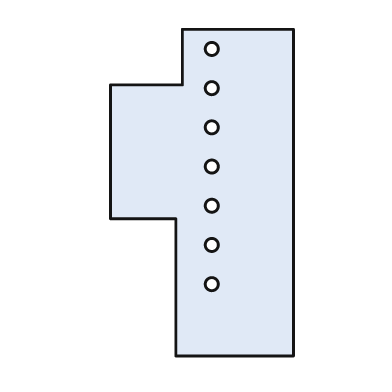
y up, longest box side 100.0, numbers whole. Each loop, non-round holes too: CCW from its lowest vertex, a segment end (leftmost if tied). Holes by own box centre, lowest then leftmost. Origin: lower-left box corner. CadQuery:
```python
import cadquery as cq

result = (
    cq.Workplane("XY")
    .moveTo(20.0, 0.0)
    .lineTo(56.0, 0.0)
    .lineTo(56.0, 100.0)
    .lineTo(22.0, 100.0)
    .lineTo(22.0, 83.0)
    .lineTo(0.0, 83.0)
    .lineTo(0.0, 42.0)
    .lineTo(20.0, 42.0)
    .close()
    .moveTo(31.0, 22.0)
    .circle(2.0)
    .moveTo(31.0, 34.0)
    .circle(2.0)
    .moveTo(31.0, 46.0)
    .circle(2.0)
    .moveTo(31.0, 58.0)
    .circle(2.0)
    .moveTo(31.0, 70.0)
    .circle(2.0)
    .moveTo(31.0, 82.0)
    .circle(2.0)
    .moveTo(31.0, 94.0)
    .circle(2.0)
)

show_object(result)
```